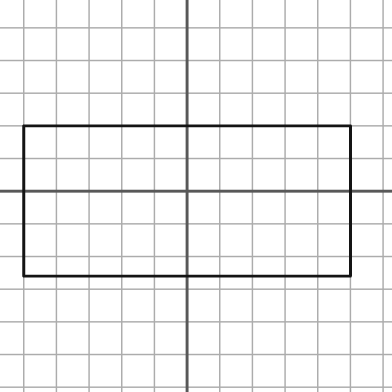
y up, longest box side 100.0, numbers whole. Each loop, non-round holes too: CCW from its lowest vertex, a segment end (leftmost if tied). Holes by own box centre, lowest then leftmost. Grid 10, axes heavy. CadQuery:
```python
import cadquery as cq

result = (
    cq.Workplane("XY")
    .moveTo(-50.0, -26.0)
    .lineTo(50.0, -26.0)
    .lineTo(50.0, 20.0)
    .lineTo(-50.0, 20.0)
    .close()
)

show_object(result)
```